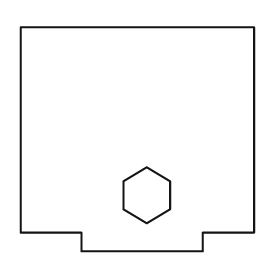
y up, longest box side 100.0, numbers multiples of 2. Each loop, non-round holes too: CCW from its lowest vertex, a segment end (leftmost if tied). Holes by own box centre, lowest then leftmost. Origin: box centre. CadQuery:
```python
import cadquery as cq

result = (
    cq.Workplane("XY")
    .moveTo(-24.0, -48.0)
    .lineTo(28.0, -48.0)
    .lineTo(28.0, -40.0)
    .lineTo(50.0, -40.0)
    .lineTo(50.0, 48.0)
    .lineTo(-50.0, 48.0)
    .lineTo(-50.0, -40.0)
    .lineTo(-24.0, -40.0)
    .close()
    .moveTo(4.0, -36.0)
    .lineTo(14.0, -30.0)
    .lineTo(14.0, -18.0)
    .lineTo(4.0, -12.0)
    .lineTo(-6.0, -18.0)
    .lineTo(-6.0, -30.0)
    .close()
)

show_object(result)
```